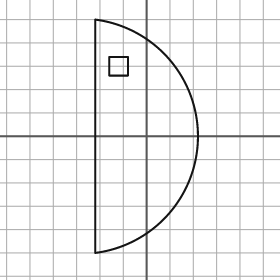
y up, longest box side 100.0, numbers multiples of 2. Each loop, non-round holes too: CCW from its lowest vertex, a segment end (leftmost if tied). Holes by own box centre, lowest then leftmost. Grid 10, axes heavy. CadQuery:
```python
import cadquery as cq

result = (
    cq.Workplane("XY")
    .moveTo(-22.0, -50.0)
    .threePointArc((22.0, 0.0), (-22.0, 50.0))
    .close()
    .moveTo(-16.0, 26.0)
    .lineTo(-8.0, 26.0)
    .lineTo(-8.0, 34.0)
    .lineTo(-16.0, 34.0)
    .close()
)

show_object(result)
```